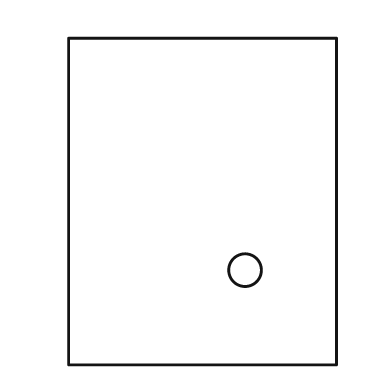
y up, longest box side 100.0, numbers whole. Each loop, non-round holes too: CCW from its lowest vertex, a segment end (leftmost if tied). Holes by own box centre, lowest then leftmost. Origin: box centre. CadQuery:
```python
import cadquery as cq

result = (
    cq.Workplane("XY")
    .moveTo(-41.0, -50.0)
    .lineTo(41.0, -50.0)
    .lineTo(41.0, 50.0)
    .lineTo(-41.0, 50.0)
    .close()
    .moveTo(13.0, -21.0)
    .circle(5.0)
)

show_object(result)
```